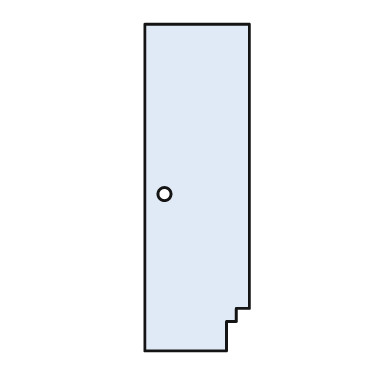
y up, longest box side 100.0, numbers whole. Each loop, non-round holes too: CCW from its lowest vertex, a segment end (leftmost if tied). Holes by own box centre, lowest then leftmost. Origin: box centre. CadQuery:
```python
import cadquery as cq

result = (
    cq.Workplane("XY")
    .moveTo(-16.0, -50.0)
    .lineTo(9.0, -50.0)
    .lineTo(9.0, -41.0)
    .lineTo(12.0, -41.0)
    .lineTo(12.0, -37.0)
    .lineTo(16.0, -37.0)
    .lineTo(16.0, 50.0)
    .lineTo(-16.0, 50.0)
    .close()
    .moveTo(-10.0, -2.0)
    .circle(2.0)
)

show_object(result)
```